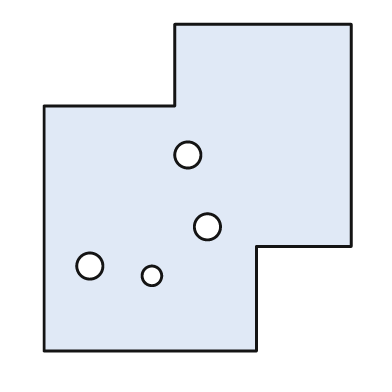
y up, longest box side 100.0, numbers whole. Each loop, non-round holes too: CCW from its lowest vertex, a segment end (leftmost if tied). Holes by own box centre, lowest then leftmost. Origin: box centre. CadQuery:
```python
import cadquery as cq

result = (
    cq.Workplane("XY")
    .moveTo(-47.0, -50.0)
    .lineTo(18.0, -50.0)
    .lineTo(18.0, -18.0)
    .lineTo(47.0, -18.0)
    .lineTo(47.0, 50.0)
    .lineTo(-7.0, 50.0)
    .lineTo(-7.0, 25.0)
    .lineTo(-47.0, 25.0)
    .close()
    .moveTo(-14.0, -27.0)
    .circle(3.0)
    .moveTo(-33.0, -24.0)
    .circle(4.0)
    .moveTo(3.0, -12.0)
    .circle(4.0)
    .moveTo(-3.0, 10.0)
    .circle(4.0)
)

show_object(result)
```